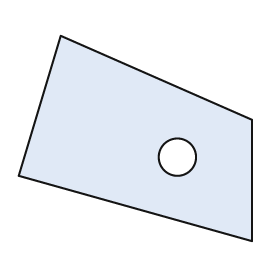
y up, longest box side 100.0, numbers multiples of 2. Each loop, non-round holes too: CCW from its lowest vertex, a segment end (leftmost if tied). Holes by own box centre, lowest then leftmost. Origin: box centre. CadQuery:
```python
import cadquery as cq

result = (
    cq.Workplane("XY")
    .moveTo(50.0, -44.0)
    .lineTo(50.0, 8.0)
    .lineTo(-32.0, 44.0)
    .lineTo(-50.0, -16.0)
    .close()
    .moveTo(18.0, -8.0)
    .circle(8.0)
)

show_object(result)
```